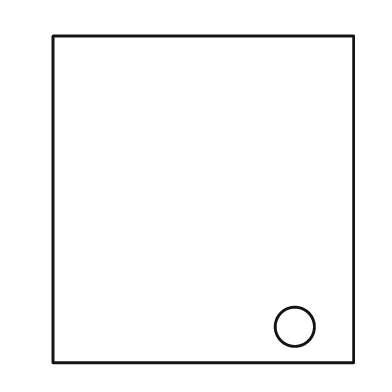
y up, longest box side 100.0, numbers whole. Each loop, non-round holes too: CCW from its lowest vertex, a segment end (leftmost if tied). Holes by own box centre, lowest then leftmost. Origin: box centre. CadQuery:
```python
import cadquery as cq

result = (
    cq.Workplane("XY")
    .moveTo(-46.0, -50.0)
    .lineTo(46.0, -50.0)
    .lineTo(46.0, 50.0)
    .lineTo(-46.0, 50.0)
    .close()
    .moveTo(28.0, -39.0)
    .circle(6.0)
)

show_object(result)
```